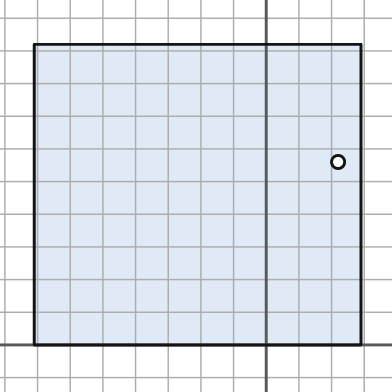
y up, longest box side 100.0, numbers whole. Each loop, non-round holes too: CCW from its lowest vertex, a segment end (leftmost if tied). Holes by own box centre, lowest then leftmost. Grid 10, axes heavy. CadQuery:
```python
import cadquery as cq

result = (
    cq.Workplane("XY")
    .moveTo(-71.0, 0.0)
    .lineTo(29.0, 0.0)
    .lineTo(29.0, 92.0)
    .lineTo(-71.0, 92.0)
    .close()
    .moveTo(22.0, 56.0)
    .circle(2.0)
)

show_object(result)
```